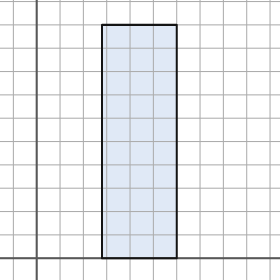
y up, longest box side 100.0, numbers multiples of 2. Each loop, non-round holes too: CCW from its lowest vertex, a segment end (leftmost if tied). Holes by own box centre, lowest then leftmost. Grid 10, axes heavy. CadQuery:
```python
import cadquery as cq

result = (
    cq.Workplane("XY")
    .moveTo(28.0, 0.0)
    .lineTo(60.0, 0.0)
    .lineTo(60.0, 100.0)
    .lineTo(28.0, 100.0)
    .close()
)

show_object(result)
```